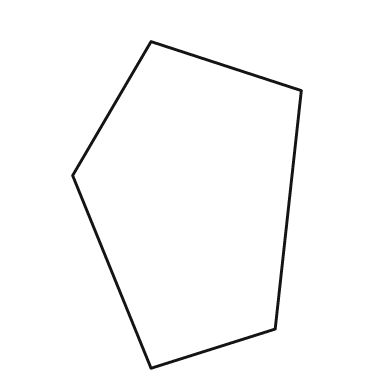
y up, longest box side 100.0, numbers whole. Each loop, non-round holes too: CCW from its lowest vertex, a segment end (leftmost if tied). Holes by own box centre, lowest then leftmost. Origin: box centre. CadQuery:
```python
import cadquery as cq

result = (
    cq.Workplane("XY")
    .moveTo(-11.0, -50.0)
    .lineTo(27.0, -38.0)
    .lineTo(35.0, 35.0)
    .lineTo(-11.0, 50.0)
    .lineTo(-35.0, 9.0)
    .close()
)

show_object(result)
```